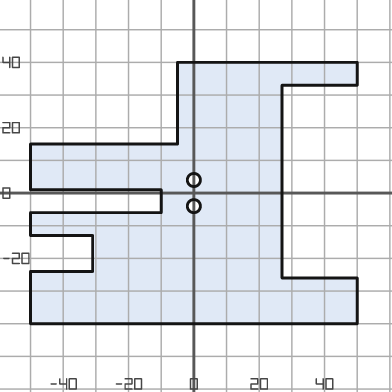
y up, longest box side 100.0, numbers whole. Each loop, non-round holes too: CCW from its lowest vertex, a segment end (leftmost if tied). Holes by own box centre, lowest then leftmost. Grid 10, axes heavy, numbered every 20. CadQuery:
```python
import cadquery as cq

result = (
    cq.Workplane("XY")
    .moveTo(-50.0, -40.0)
    .lineTo(50.0, -40.0)
    .lineTo(50.0, -26.0)
    .lineTo(27.0, -26.0)
    .lineTo(27.0, 33.0)
    .lineTo(50.0, 33.0)
    .lineTo(50.0, 40.0)
    .lineTo(-5.0, 40.0)
    .lineTo(-5.0, 15.0)
    .lineTo(-50.0, 15.0)
    .lineTo(-50.0, 1.0)
    .lineTo(-10.0, 1.0)
    .lineTo(-10.0, -6.0)
    .lineTo(-50.0, -6.0)
    .lineTo(-50.0, -13.0)
    .lineTo(-31.0, -13.0)
    .lineTo(-31.0, -24.0)
    .lineTo(-50.0, -24.0)
    .close()
    .moveTo(0.0, -4.0)
    .circle(2.0)
    .moveTo(0.0, 4.0)
    .circle(2.0)
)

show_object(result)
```